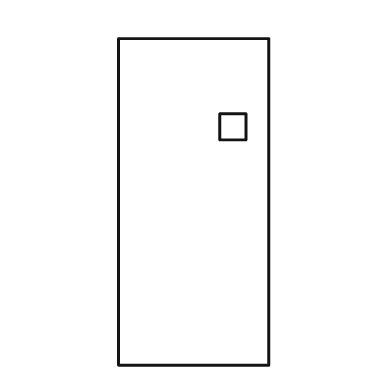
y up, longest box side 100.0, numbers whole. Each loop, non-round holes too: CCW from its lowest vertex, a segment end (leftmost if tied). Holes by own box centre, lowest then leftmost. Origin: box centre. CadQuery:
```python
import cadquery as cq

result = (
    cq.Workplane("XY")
    .moveTo(-23.0, -50.0)
    .lineTo(23.0, -50.0)
    .lineTo(23.0, 50.0)
    .lineTo(-23.0, 50.0)
    .close()
    .moveTo(8.0, 19.0)
    .lineTo(16.0, 19.0)
    .lineTo(16.0, 27.0)
    .lineTo(8.0, 27.0)
    .close()
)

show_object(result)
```